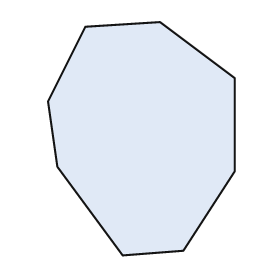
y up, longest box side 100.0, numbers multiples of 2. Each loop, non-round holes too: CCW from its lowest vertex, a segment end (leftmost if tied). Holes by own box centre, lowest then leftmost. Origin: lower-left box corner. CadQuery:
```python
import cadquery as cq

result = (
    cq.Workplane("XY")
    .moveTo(32.0, 0.0)
    .lineTo(58.0, 2.0)
    .lineTo(80.0, 36.0)
    .lineTo(80.0, 76.0)
    .lineTo(48.0, 100.0)
    .lineTo(16.0, 98.0)
    .lineTo(0.0, 66.0)
    .lineTo(4.0, 38.0)
    .close()
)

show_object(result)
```